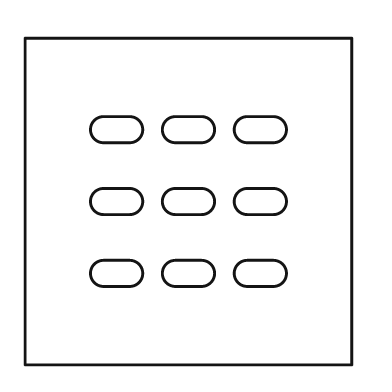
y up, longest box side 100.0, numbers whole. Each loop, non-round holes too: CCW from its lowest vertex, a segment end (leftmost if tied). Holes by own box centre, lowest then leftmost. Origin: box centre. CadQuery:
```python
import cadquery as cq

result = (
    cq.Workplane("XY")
    .moveTo(-50.0, -50.0)
    .lineTo(50.0, -50.0)
    .lineTo(50.0, 50.0)
    .lineTo(-50.0, 50.0)
    .close()
    .moveTo(-26.0, -26.0)
    .lineTo(-18.0, -26.0)
    .threePointArc((-14.0, -22.0), (-18.0, -18.0))
    .lineTo(-26.0, -18.0)
    .threePointArc((-30.0, -22.0), (-26.0, -26.0))
    .close()
    .moveTo(-4.0, -26.0)
    .lineTo(4.0, -26.0)
    .threePointArc((8.0, -22.0), (4.0, -18.0))
    .lineTo(-4.0, -18.0)
    .threePointArc((-8.0, -22.0), (-4.0, -26.0))
    .close()
    .moveTo(18.0, -26.0)
    .lineTo(26.0, -26.0)
    .threePointArc((30.0, -22.0), (26.0, -18.0))
    .lineTo(18.0, -18.0)
    .threePointArc((14.0, -22.0), (18.0, -26.0))
    .close()
    .moveTo(-26.0, -4.0)
    .lineTo(-18.0, -4.0)
    .threePointArc((-14.0, 0.0), (-18.0, 4.0))
    .lineTo(-26.0, 4.0)
    .threePointArc((-30.0, 0.0), (-26.0, -4.0))
    .close()
    .moveTo(-4.0, -4.0)
    .lineTo(4.0, -4.0)
    .threePointArc((8.0, 0.0), (4.0, 4.0))
    .lineTo(-4.0, 4.0)
    .threePointArc((-8.0, 0.0), (-4.0, -4.0))
    .close()
    .moveTo(18.0, -4.0)
    .lineTo(26.0, -4.0)
    .threePointArc((30.0, 0.0), (26.0, 4.0))
    .lineTo(18.0, 4.0)
    .threePointArc((14.0, 0.0), (18.0, -4.0))
    .close()
    .moveTo(-26.0, 18.0)
    .lineTo(-18.0, 18.0)
    .threePointArc((-14.0, 22.0), (-18.0, 26.0))
    .lineTo(-26.0, 26.0)
    .threePointArc((-30.0, 22.0), (-26.0, 18.0))
    .close()
    .moveTo(-4.0, 18.0)
    .lineTo(4.0, 18.0)
    .threePointArc((8.0, 22.0), (4.0, 26.0))
    .lineTo(-4.0, 26.0)
    .threePointArc((-8.0, 22.0), (-4.0, 18.0))
    .close()
    .moveTo(18.0, 18.0)
    .lineTo(26.0, 18.0)
    .threePointArc((30.0, 22.0), (26.0, 26.0))
    .lineTo(18.0, 26.0)
    .threePointArc((14.0, 22.0), (18.0, 18.0))
    .close()
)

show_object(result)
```